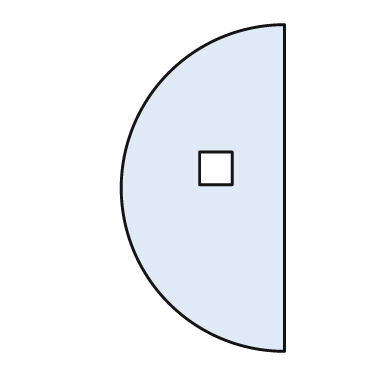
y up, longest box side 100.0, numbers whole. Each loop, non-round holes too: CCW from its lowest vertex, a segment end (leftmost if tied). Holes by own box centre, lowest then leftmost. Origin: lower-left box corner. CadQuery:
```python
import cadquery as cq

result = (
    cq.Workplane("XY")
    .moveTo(50.0, 0.0)
    .lineTo(50.0, 100.0)
    .threePointArc((0.0, 50.0), (50.0, 0.0))
    .close()
    .moveTo(24.0, 51.0)
    .lineTo(34.0, 51.0)
    .lineTo(34.0, 61.0)
    .lineTo(24.0, 61.0)
    .close()
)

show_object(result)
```